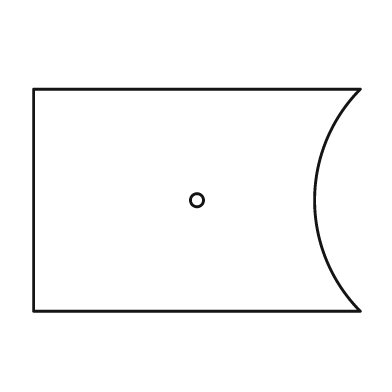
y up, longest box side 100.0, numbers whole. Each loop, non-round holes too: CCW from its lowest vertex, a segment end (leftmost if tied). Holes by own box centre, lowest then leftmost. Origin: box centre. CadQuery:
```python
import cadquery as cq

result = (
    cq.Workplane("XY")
    .moveTo(-50.0, -34.0)
    .lineTo(50.0, -34.0)
    .threePointArc((36.0, 0.0), (50.0, 34.0))
    .lineTo(-50.0, 34.0)
    .close()
    .moveTo(0.0, 0.0)
    .circle(2.0)
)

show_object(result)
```